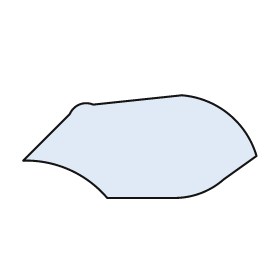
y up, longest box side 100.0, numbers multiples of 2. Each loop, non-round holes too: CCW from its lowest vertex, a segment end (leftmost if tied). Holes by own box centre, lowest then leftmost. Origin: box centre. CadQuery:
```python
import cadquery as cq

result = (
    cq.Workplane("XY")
    .moveTo(-14.0, -22.0)
    .lineTo(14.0, -22.0)
    .threePointArc((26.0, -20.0), (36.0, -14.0))
    .lineTo(50.0, -4.0)
    .threePointArc((38.0, 14.0), (18.0, 22.0))
    .lineTo(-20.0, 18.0)
    .threePointArc((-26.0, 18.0), (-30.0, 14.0))
    .lineTo(-50.0, -6.0)
    .threePointArc((-30.0, -10.0), (-14.0, -22.0))
    .close()
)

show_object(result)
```